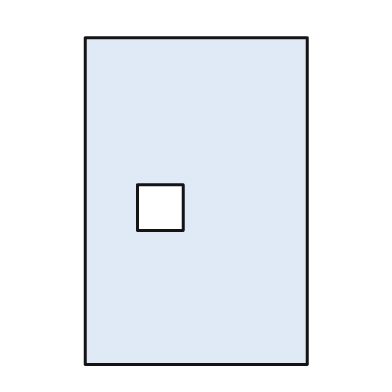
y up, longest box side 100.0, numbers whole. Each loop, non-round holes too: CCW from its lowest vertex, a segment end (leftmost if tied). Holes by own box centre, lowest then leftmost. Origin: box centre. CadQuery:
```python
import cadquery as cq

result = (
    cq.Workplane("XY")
    .moveTo(-34.0, -50.0)
    .lineTo(34.0, -50.0)
    .lineTo(34.0, 50.0)
    .lineTo(-34.0, 50.0)
    .close()
    .moveTo(-18.0, -9.0)
    .lineTo(-4.0, -9.0)
    .lineTo(-4.0, 5.0)
    .lineTo(-18.0, 5.0)
    .close()
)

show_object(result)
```